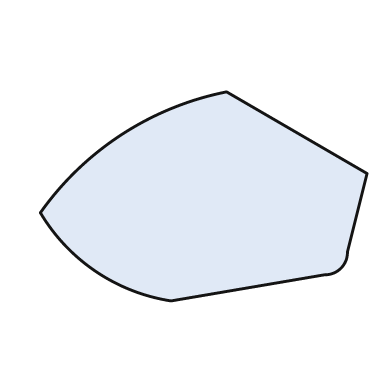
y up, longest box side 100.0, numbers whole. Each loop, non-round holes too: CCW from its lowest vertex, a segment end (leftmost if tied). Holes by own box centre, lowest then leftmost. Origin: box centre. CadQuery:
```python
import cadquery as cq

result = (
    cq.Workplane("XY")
    .moveTo(-10.0, -32.0)
    .lineTo(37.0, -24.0)
    .threePointArc((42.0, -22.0), (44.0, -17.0))
    .lineTo(50.0, 7.0)
    .lineTo(7.0, 32.0)
    .threePointArc((-25.0, 19.0), (-50.0, -5.0))
    .threePointArc((-33.0, -23.0), (-10.0, -32.0))
    .close()
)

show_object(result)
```